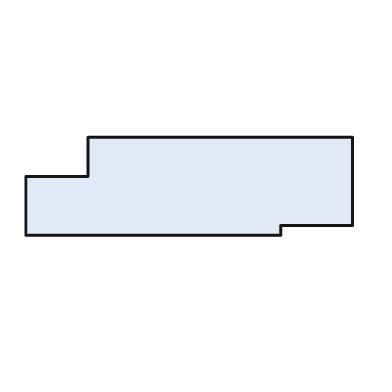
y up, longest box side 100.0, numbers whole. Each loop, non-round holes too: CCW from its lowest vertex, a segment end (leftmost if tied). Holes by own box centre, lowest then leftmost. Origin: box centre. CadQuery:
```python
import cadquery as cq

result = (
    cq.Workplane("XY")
    .moveTo(-50.0, -15.0)
    .lineTo(28.0, -15.0)
    .lineTo(28.0, -12.0)
    .lineTo(50.0, -12.0)
    .lineTo(50.0, 15.0)
    .lineTo(-31.0, 15.0)
    .lineTo(-31.0, 3.0)
    .lineTo(-50.0, 3.0)
    .close()
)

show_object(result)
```